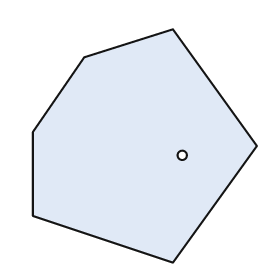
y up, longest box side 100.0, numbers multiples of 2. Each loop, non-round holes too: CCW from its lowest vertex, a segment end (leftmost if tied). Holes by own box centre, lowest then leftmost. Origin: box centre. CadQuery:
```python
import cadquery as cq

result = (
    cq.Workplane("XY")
    .moveTo(12.0, -50.0)
    .lineTo(48.0, 0.0)
    .lineTo(12.0, 50.0)
    .lineTo(-26.0, 38.0)
    .lineTo(-48.0, 6.0)
    .lineTo(-48.0, -30.0)
    .close()
    .moveTo(16.0, -4.0)
    .circle(2.0)
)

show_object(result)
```